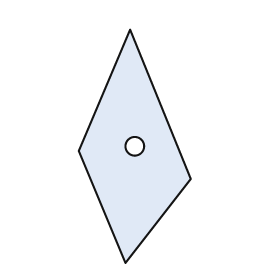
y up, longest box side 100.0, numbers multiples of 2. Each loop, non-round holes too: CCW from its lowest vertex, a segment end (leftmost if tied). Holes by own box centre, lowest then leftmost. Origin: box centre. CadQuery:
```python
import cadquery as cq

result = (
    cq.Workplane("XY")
    .moveTo(-4.0, -50.0)
    .lineTo(24.0, -14.0)
    .lineTo(-2.0, 50.0)
    .lineTo(-24.0, -2.0)
    .close()
    .moveTo(0.0, 0.0)
    .circle(4.0)
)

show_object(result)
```